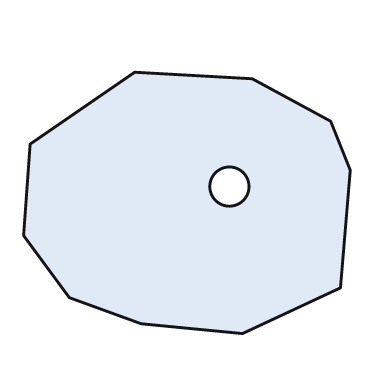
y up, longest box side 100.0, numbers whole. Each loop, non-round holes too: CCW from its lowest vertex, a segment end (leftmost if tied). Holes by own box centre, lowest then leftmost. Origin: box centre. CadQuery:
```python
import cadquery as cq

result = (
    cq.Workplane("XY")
    .moveTo(17.0, -40.0)
    .lineTo(47.0, -26.0)
    .lineTo(50.0, 10.0)
    .lineTo(44.0, 25.0)
    .lineTo(20.0, 38.0)
    .lineTo(-16.0, 40.0)
    .lineTo(-48.0, 18.0)
    .lineTo(-50.0, -10.0)
    .lineTo(-36.0, -29.0)
    .lineTo(-14.0, -37.0)
    .close()
    .moveTo(13.0, 5.0)
    .circle(6.0)
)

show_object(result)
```